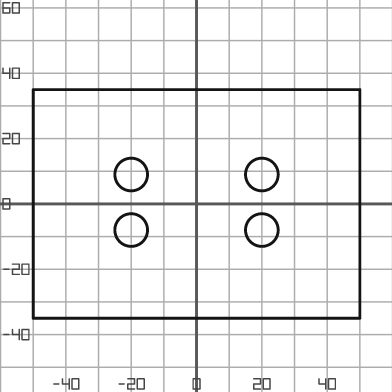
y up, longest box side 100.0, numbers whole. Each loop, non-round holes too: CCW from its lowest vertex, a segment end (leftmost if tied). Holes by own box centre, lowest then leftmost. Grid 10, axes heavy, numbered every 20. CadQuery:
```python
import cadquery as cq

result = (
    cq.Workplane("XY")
    .moveTo(-50.0, -35.0)
    .lineTo(50.0, -35.0)
    .lineTo(50.0, 35.0)
    .lineTo(-50.0, 35.0)
    .close()
    .moveTo(-20.0, -8.0)
    .circle(5.0)
    .moveTo(20.0, -8.0)
    .circle(5.0)
    .moveTo(-20.0, 9.0)
    .circle(5.0)
    .moveTo(20.0, 9.0)
    .circle(5.0)
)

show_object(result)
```